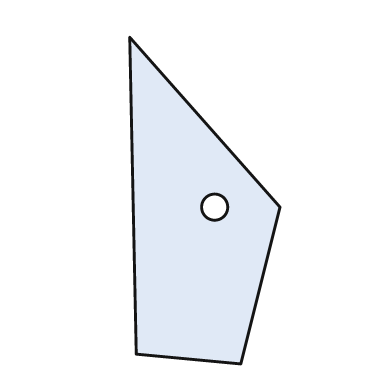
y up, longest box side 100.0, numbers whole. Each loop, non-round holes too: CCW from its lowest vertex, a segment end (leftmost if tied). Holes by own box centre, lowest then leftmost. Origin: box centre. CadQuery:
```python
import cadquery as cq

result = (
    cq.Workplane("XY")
    .moveTo(11.0, -50.0)
    .lineTo(23.0, -2.0)
    .lineTo(-23.0, 50.0)
    .lineTo(-21.0, -47.0)
    .close()
    .moveTo(3.0, -2.0)
    .circle(4.0)
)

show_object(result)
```